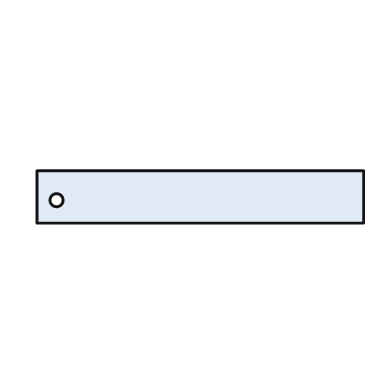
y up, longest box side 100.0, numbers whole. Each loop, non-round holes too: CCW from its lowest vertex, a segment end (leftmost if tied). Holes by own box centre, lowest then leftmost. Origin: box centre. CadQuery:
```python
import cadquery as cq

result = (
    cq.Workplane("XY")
    .moveTo(-50.0, -8.0)
    .lineTo(50.0, -8.0)
    .lineTo(50.0, 8.0)
    .lineTo(-50.0, 8.0)
    .close()
    .moveTo(-44.0, -1.0)
    .circle(2.0)
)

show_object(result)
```